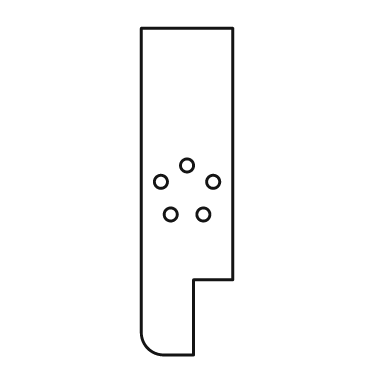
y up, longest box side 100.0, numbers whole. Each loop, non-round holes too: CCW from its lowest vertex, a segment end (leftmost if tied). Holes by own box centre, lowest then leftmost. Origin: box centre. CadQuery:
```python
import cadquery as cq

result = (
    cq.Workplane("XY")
    .moveTo(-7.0, -50.0)
    .lineTo(2.0, -50.0)
    .lineTo(2.0, -27.0)
    .lineTo(14.0, -27.0)
    .lineTo(14.0, 50.0)
    .lineTo(-14.0, 50.0)
    .lineTo(-14.0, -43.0)
    .threePointArc((-12.0, -48.0), (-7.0, -50.0))
    .close()
    .moveTo(-5.0, -7.0)
    .circle(2.0)
    .moveTo(5.0, -7.0)
    .circle(2.0)
    .moveTo(-8.0, 3.0)
    .circle(2.0)
    .moveTo(8.0, 3.0)
    .circle(2.0)
    .moveTo(0.0, 8.0)
    .circle(2.0)
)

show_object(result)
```